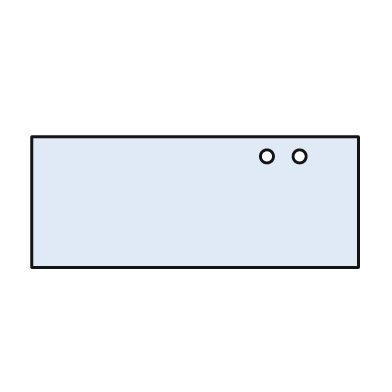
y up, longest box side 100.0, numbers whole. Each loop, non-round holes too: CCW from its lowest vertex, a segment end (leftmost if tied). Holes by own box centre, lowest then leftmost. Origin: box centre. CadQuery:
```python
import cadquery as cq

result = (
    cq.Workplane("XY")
    .moveTo(-50.0, -20.0)
    .lineTo(50.0, -20.0)
    .lineTo(50.0, 20.0)
    .lineTo(-50.0, 20.0)
    .close()
    .moveTo(22.0, 14.0)
    .circle(2.0)
    .moveTo(32.0, 14.0)
    .circle(2.0)
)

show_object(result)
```